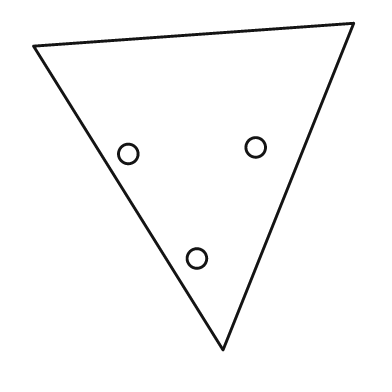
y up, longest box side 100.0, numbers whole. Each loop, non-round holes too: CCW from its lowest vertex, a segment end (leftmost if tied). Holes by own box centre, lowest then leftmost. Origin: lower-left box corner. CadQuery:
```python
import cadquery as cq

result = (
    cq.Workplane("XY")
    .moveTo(58.0, 0.0)
    .lineTo(98.0, 100.0)
    .lineTo(0.0, 93.0)
    .close()
    .moveTo(50.0, 28.0)
    .circle(3.0)
    .moveTo(29.0, 60.0)
    .circle(3.0)
    .moveTo(68.0, 62.0)
    .circle(3.0)
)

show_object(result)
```